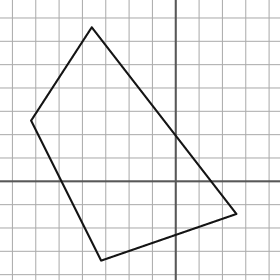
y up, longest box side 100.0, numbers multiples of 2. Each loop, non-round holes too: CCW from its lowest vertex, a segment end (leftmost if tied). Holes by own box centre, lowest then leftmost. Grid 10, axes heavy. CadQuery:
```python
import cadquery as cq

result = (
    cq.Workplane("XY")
    .moveTo(-32.0, -34.0)
    .lineTo(26.0, -14.0)
    .lineTo(-36.0, 66.0)
    .lineTo(-62.0, 26.0)
    .close()
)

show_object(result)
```